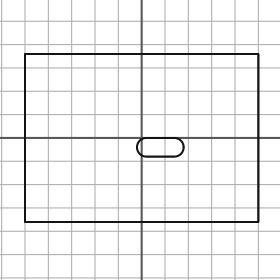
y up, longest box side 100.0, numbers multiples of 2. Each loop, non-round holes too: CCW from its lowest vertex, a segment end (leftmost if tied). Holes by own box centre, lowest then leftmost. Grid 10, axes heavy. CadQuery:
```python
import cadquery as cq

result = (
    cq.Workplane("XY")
    .moveTo(-50.0, -36.0)
    .lineTo(50.0, -36.0)
    .lineTo(50.0, 36.0)
    .lineTo(-50.0, 36.0)
    .close()
    .moveTo(2.0, -8.0)
    .lineTo(14.0, -8.0)
    .threePointArc((18.0, -4.0), (14.0, 0.0))
    .lineTo(2.0, 0.0)
    .threePointArc((-2.0, -4.0), (2.0, -8.0))
    .close()
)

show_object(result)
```